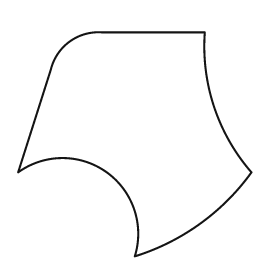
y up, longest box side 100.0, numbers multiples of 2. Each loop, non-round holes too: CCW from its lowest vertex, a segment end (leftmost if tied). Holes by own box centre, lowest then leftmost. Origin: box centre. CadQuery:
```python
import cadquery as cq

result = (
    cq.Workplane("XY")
    .moveTo(0.0, -48.0)
    .threePointArc((28.0, -34.0), (50.0, -12.0))
    .threePointArc((34.0, 16.0), (30.0, 48.0))
    .lineTo(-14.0, 48.0)
    .threePointArc((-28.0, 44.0), (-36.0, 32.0))
    .lineTo(-50.0, -12.0)
    .threePointArc((-12.0, -12.0), (0.0, -48.0))
    .close()
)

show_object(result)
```